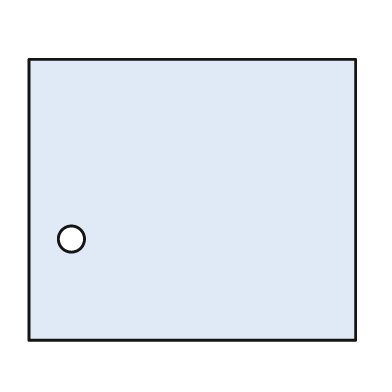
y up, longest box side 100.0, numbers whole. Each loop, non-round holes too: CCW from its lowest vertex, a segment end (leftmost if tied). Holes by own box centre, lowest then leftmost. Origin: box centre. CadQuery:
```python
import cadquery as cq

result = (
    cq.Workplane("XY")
    .moveTo(-50.0, -43.0)
    .lineTo(50.0, -43.0)
    .lineTo(50.0, 43.0)
    .lineTo(-50.0, 43.0)
    .close()
    .moveTo(-37.0, -12.0)
    .circle(4.0)
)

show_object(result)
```